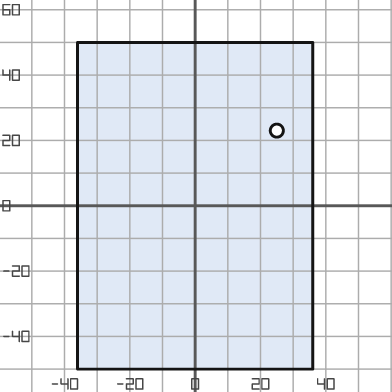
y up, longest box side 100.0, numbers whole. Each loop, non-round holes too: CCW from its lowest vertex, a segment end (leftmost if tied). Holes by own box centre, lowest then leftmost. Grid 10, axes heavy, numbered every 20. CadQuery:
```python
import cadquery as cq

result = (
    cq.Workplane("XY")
    .moveTo(-36.0, -50.0)
    .lineTo(36.0, -50.0)
    .lineTo(36.0, 50.0)
    .lineTo(-36.0, 50.0)
    .close()
    .moveTo(25.0, 23.0)
    .circle(2.0)
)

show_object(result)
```